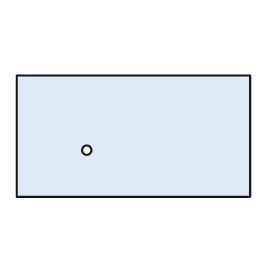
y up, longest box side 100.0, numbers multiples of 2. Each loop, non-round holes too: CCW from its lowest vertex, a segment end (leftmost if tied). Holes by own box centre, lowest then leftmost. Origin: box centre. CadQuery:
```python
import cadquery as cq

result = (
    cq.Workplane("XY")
    .moveTo(-50.0, -26.0)
    .lineTo(50.0, -26.0)
    .lineTo(50.0, 26.0)
    .lineTo(-50.0, 26.0)
    .close()
    .moveTo(-20.0, -6.0)
    .circle(2.0)
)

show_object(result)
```